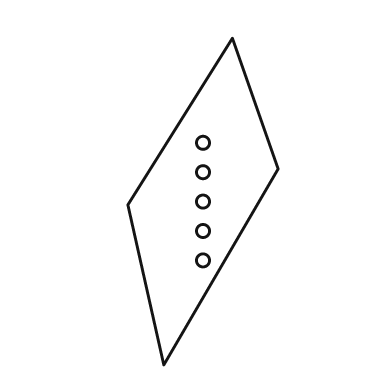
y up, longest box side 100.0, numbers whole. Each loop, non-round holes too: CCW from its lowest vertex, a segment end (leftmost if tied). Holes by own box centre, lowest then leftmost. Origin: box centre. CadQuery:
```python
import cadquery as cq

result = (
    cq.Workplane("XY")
    .moveTo(-12.0, -50.0)
    .lineTo(23.0, 10.0)
    .lineTo(9.0, 50.0)
    .lineTo(-23.0, -1.0)
    .close()
    .moveTo(0.0, -18.0)
    .circle(2.0)
    .moveTo(0.0, -9.0)
    .circle(2.0)
    .moveTo(0.0, 0.0)
    .circle(2.0)
    .moveTo(0.0, 9.0)
    .circle(2.0)
    .moveTo(0.0, 18.0)
    .circle(2.0)
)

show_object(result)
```